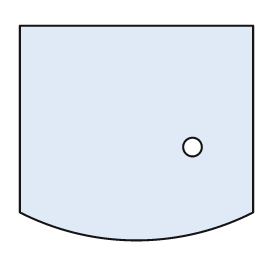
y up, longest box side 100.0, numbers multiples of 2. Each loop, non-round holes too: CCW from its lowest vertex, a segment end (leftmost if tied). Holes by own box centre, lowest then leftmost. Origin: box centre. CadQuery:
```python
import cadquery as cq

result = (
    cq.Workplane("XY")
    .moveTo(-50.0, -34.0)
    .threePointArc((0.0, -46.0), (50.0, -34.0))
    .lineTo(50.0, 46.0)
    .lineTo(-50.0, 46.0)
    .close()
    .moveTo(24.0, -6.0)
    .circle(4.0)
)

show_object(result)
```